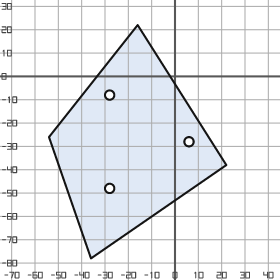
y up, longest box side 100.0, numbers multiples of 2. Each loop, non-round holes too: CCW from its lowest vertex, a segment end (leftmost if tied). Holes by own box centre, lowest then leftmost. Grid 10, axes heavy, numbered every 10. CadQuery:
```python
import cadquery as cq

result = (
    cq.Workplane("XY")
    .moveTo(-36.0, -78.0)
    .lineTo(22.0, -38.0)
    .lineTo(-16.0, 22.0)
    .lineTo(-54.0, -26.0)
    .close()
    .moveTo(-28.0, -48.0)
    .circle(2.0)
    .moveTo(6.0, -28.0)
    .circle(2.0)
    .moveTo(-28.0, -8.0)
    .circle(2.0)
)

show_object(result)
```